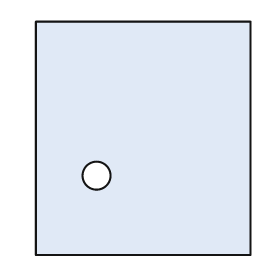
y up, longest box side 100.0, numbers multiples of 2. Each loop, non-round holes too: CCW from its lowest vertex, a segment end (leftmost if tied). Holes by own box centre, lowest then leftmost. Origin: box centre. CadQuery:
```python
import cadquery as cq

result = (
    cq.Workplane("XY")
    .moveTo(-46.0, -50.0)
    .lineTo(46.0, -50.0)
    .lineTo(46.0, 50.0)
    .lineTo(-46.0, 50.0)
    .close()
    .moveTo(-20.0, -16.0)
    .circle(6.0)
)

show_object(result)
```